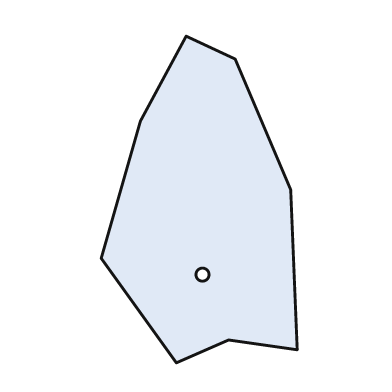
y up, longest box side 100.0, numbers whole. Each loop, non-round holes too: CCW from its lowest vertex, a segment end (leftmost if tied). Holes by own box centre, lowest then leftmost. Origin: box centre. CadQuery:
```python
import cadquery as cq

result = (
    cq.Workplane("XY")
    .moveTo(-7.0, -50.0)
    .lineTo(9.0, -43.0)
    .lineTo(30.0, -46.0)
    .lineTo(28.0, 3.0)
    .lineTo(11.0, 43.0)
    .lineTo(-4.0, 50.0)
    .lineTo(-18.0, 24.0)
    .lineTo(-30.0, -18.0)
    .close()
    .moveTo(1.0, -23.0)
    .circle(2.0)
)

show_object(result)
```